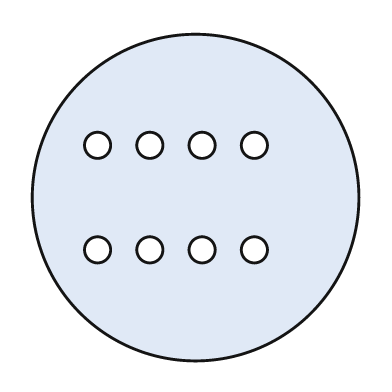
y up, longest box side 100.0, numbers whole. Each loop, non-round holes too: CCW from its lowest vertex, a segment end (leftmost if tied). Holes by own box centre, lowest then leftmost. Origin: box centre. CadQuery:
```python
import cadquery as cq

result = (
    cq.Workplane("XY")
    .moveTo(0.0, 0.0)
    .circle(50.0)
    .moveTo(-30.0, -16.0)
    .circle(4.0)
    .moveTo(-14.0, -16.0)
    .circle(4.0)
    .moveTo(2.0, -16.0)
    .circle(4.0)
    .moveTo(18.0, -16.0)
    .circle(4.0)
    .moveTo(-30.0, 16.0)
    .circle(4.0)
    .moveTo(-14.0, 16.0)
    .circle(4.0)
    .moveTo(2.0, 16.0)
    .circle(4.0)
    .moveTo(18.0, 16.0)
    .circle(4.0)
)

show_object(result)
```